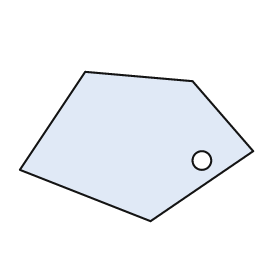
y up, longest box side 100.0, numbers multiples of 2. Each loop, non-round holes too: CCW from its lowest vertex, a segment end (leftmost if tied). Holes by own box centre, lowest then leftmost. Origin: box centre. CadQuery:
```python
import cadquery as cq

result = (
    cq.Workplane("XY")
    .moveTo(6.0, -32.0)
    .lineTo(50.0, -2.0)
    .lineTo(24.0, 28.0)
    .lineTo(-22.0, 32.0)
    .lineTo(-50.0, -10.0)
    .close()
    .moveTo(28.0, -6.0)
    .circle(4.0)
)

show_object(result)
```